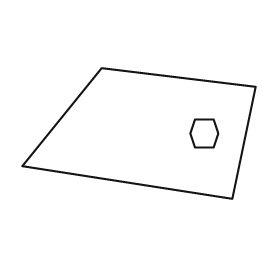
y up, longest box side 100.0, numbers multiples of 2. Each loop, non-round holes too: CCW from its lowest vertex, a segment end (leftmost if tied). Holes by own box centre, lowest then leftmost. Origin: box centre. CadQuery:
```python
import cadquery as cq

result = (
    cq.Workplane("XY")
    .moveTo(40.0, -28.0)
    .lineTo(50.0, 20.0)
    .lineTo(-16.0, 28.0)
    .lineTo(-50.0, -14.0)
    .close()
    .moveTo(24.0, -6.0)
    .lineTo(32.0, -6.0)
    .lineTo(34.0, 0.0)
    .lineTo(32.0, 6.0)
    .lineTo(24.0, 6.0)
    .lineTo(22.0, 0.0)
    .close()
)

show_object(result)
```